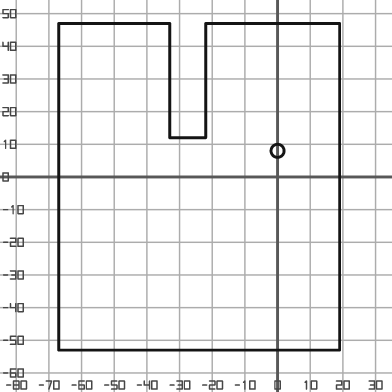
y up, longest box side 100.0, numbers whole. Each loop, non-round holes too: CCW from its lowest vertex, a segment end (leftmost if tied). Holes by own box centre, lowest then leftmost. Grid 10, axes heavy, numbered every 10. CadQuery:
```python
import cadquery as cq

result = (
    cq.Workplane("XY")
    .moveTo(-67.0, -53.0)
    .lineTo(19.0, -53.0)
    .lineTo(19.0, 47.0)
    .lineTo(-22.0, 47.0)
    .lineTo(-22.0, 12.0)
    .lineTo(-33.0, 12.0)
    .lineTo(-33.0, 47.0)
    .lineTo(-67.0, 47.0)
    .close()
    .moveTo(0.0, 8.0)
    .circle(2.0)
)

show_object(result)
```